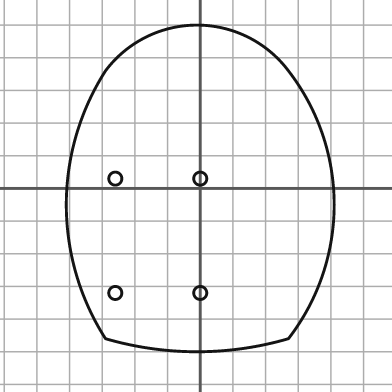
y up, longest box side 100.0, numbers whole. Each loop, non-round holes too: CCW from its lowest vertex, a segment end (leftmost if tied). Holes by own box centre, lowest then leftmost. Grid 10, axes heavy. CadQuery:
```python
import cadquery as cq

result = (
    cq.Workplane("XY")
    .moveTo(-29.0, -46.0)
    .threePointArc((-1.0, -50.0), (27.0, -46.0))
    .threePointArc((41.0, -5.0), (27.0, 36.0))
    .threePointArc((-1.0, 50.0), (-29.0, 36.0))
    .threePointArc((-41.0, -5.0), (-29.0, -46.0))
    .close()
    .moveTo(-26.0, -32.0)
    .circle(2.0)
    .moveTo(0.0, -32.0)
    .circle(2.0)
    .moveTo(-26.0, 3.0)
    .circle(2.0)
    .moveTo(0.0, 3.0)
    .circle(2.0)
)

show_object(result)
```